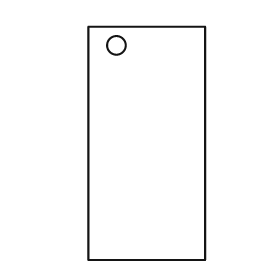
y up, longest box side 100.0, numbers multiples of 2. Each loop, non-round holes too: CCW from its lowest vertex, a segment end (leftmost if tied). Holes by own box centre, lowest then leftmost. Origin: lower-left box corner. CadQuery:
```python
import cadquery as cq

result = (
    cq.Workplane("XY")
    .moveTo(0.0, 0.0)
    .lineTo(50.0, 0.0)
    .lineTo(50.0, 100.0)
    .lineTo(0.0, 100.0)
    .close()
    .moveTo(12.0, 92.0)
    .circle(4.0)
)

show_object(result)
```